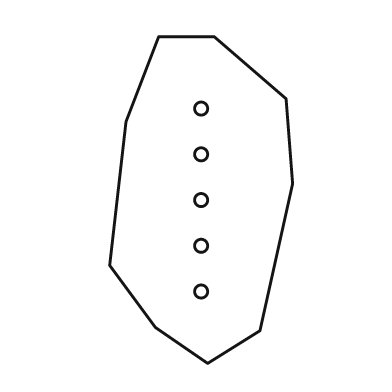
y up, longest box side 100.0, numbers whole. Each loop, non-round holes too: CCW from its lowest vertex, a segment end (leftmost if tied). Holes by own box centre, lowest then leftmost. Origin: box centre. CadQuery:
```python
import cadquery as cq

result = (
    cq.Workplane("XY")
    .moveTo(2.0, -50.0)
    .lineTo(18.0, -40.0)
    .lineTo(28.0, 5.0)
    .lineTo(26.0, 31.0)
    .lineTo(4.0, 50.0)
    .lineTo(-13.0, 50.0)
    .lineTo(-23.0, 24.0)
    .lineTo(-28.0, -20.0)
    .lineTo(-14.0, -39.0)
    .close()
    .moveTo(0.0, -28.0)
    .circle(2.0)
    .moveTo(0.0, -14.0)
    .circle(2.0)
    .moveTo(0.0, 0.0)
    .circle(2.0)
    .moveTo(0.0, 14.0)
    .circle(2.0)
    .moveTo(0.0, 28.0)
    .circle(2.0)
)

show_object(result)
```